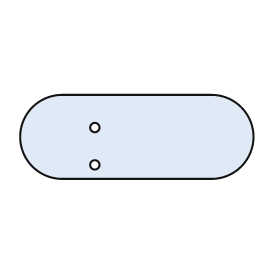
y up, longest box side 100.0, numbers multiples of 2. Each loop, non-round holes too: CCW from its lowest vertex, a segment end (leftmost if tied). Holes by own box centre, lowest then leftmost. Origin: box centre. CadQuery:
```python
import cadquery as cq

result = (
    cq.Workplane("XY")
    .moveTo(-32.0, -18.0)
    .lineTo(32.0, -18.0)
    .threePointArc((50.0, 0.0), (32.0, 18.0))
    .lineTo(-32.0, 18.0)
    .threePointArc((-50.0, 0.0), (-32.0, -18.0))
    .close()
    .moveTo(-18.0, -12.0)
    .circle(2.0)
    .moveTo(-18.0, 4.0)
    .circle(2.0)
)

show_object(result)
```